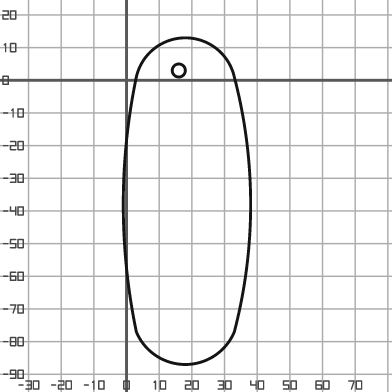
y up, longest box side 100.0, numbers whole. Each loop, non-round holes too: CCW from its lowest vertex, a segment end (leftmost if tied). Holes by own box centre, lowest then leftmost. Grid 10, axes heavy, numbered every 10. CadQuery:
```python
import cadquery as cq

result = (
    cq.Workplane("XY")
    .moveTo(3.0, -77.0)
    .threePointArc((18.0, -87.0), (33.0, -77.0))
    .threePointArc((38.0, -38.0), (33.0, 1.0))
    .threePointArc((18.0, 13.0), (3.0, 1.0))
    .threePointArc((-1.0, -38.0), (3.0, -77.0))
    .close()
    .moveTo(16.0, 3.0)
    .circle(2.0)
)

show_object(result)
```